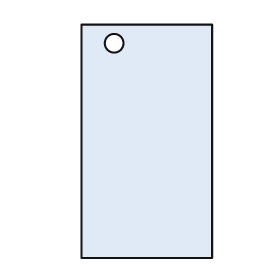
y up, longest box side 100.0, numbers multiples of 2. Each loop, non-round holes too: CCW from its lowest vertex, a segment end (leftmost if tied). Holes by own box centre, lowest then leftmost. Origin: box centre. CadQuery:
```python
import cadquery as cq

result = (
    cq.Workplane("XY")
    .moveTo(-28.0, -50.0)
    .lineTo(28.0, -50.0)
    .lineTo(28.0, 50.0)
    .lineTo(-28.0, 50.0)
    .close()
    .moveTo(-14.0, 42.0)
    .circle(4.0)
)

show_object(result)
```